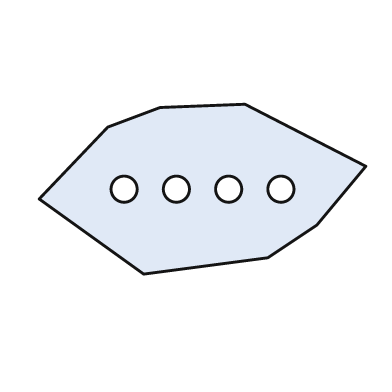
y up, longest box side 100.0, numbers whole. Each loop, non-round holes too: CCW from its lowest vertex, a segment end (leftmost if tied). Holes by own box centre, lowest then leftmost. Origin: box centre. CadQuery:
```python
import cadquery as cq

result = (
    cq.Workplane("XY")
    .moveTo(-18.0, -26.0)
    .lineTo(20.0, -21.0)
    .lineTo(35.0, -11.0)
    .lineTo(50.0, 7.0)
    .lineTo(13.0, 26.0)
    .lineTo(-13.0, 25.0)
    .lineTo(-29.0, 19.0)
    .lineTo(-50.0, -3.0)
    .close()
    .moveTo(-24.0, 0.0)
    .circle(4.0)
    .moveTo(-8.0, 0.0)
    .circle(4.0)
    .moveTo(8.0, 0.0)
    .circle(4.0)
    .moveTo(24.0, 0.0)
    .circle(4.0)
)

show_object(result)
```